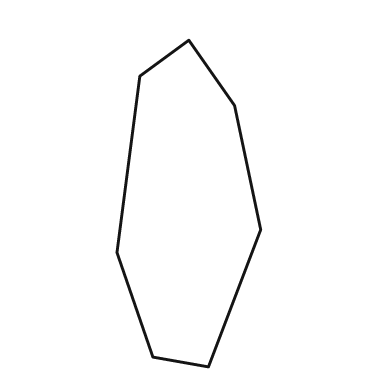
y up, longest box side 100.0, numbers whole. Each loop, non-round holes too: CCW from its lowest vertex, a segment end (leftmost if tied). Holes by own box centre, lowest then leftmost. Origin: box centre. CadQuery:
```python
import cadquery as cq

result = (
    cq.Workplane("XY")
    .moveTo(6.0, -50.0)
    .lineTo(22.0, -8.0)
    .lineTo(14.0, 30.0)
    .lineTo(0.0, 50.0)
    .lineTo(-15.0, 39.0)
    .lineTo(-22.0, -15.0)
    .lineTo(-11.0, -47.0)
    .close()
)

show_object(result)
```